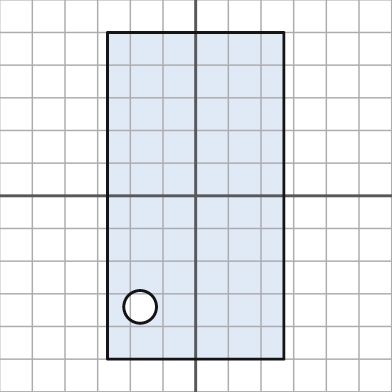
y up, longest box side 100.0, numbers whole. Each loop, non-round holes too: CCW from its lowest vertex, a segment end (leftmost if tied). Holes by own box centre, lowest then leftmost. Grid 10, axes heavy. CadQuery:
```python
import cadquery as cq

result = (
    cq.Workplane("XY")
    .moveTo(-27.0, -50.0)
    .lineTo(27.0, -50.0)
    .lineTo(27.0, 50.0)
    .lineTo(-27.0, 50.0)
    .close()
    .moveTo(-17.0, -34.0)
    .circle(5.0)
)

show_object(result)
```